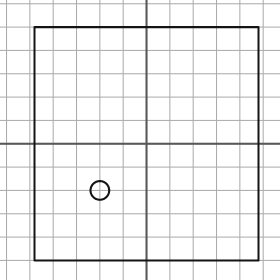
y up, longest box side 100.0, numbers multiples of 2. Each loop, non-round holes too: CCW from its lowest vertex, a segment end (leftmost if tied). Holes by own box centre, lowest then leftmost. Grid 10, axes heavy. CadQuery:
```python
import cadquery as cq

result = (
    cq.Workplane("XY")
    .moveTo(-48.0, -50.0)
    .lineTo(48.0, -50.0)
    .lineTo(48.0, 50.0)
    .lineTo(-48.0, 50.0)
    .close()
    .moveTo(-20.0, -20.0)
    .circle(4.0)
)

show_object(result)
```